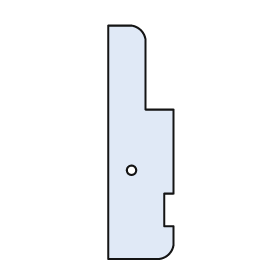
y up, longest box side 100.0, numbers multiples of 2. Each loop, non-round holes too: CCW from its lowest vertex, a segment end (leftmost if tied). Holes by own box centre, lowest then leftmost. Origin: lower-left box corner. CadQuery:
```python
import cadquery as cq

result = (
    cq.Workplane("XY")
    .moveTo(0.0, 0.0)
    .lineTo(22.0, 0.0)
    .threePointArc((26.0, 2.0), (28.0, 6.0))
    .lineTo(28.0, 14.0)
    .lineTo(24.0, 14.0)
    .lineTo(24.0, 28.0)
    .lineTo(28.0, 28.0)
    .lineTo(28.0, 64.0)
    .lineTo(16.0, 64.0)
    .lineTo(16.0, 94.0)
    .threePointArc((14.0, 98.0), (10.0, 100.0))
    .lineTo(0.0, 100.0)
    .close()
    .moveTo(10.0, 38.0)
    .circle(2.0)
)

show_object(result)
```